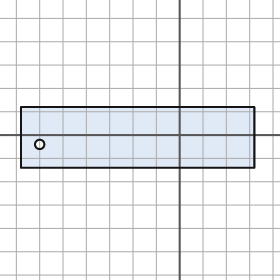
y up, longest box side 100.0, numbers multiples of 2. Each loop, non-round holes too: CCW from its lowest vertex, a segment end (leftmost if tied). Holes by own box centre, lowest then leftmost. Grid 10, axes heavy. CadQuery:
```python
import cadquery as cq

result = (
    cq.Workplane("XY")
    .moveTo(-68.0, -14.0)
    .lineTo(32.0, -14.0)
    .lineTo(32.0, 12.0)
    .lineTo(-68.0, 12.0)
    .close()
    .moveTo(-60.0, -4.0)
    .circle(2.0)
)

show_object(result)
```